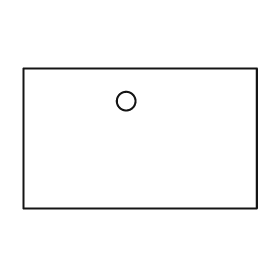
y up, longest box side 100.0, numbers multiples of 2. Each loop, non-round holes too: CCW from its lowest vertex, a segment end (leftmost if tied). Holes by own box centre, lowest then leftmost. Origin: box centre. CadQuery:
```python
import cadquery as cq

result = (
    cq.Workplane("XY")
    .moveTo(-50.0, -30.0)
    .lineTo(50.0, -30.0)
    .lineTo(50.0, 30.0)
    .lineTo(-50.0, 30.0)
    .close()
    .moveTo(-6.0, 16.0)
    .circle(4.0)
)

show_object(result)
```